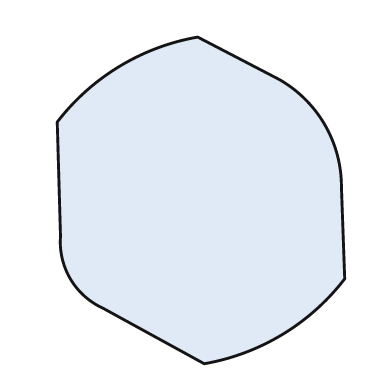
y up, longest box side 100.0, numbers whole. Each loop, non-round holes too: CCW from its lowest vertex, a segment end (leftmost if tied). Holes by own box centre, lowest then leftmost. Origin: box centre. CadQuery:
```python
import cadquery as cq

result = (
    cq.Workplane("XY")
    .moveTo(1.0, -50.0)
    .threePointArc((25.0, -41.0), (44.0, -24.0))
    .lineTo(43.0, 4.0)
    .threePointArc((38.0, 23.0), (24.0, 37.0))
    .lineTo(-1.0, 50.0)
    .threePointArc((-25.0, 41.0), (-44.0, 24.0))
    .lineTo(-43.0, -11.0)
    .threePointArc((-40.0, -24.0), (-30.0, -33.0))
    .close()
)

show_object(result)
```